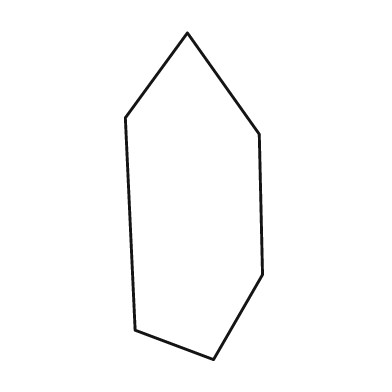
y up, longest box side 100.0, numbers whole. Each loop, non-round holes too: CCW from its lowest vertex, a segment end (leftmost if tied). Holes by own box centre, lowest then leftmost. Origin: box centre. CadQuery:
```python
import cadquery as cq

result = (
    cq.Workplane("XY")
    .moveTo(6.0, -50.0)
    .lineTo(21.0, -24.0)
    .lineTo(20.0, 19.0)
    .lineTo(-2.0, 50.0)
    .lineTo(-21.0, 24.0)
    .lineTo(-18.0, -41.0)
    .close()
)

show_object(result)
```